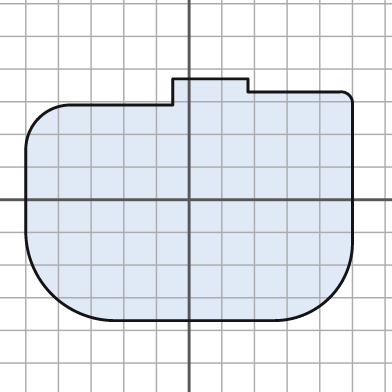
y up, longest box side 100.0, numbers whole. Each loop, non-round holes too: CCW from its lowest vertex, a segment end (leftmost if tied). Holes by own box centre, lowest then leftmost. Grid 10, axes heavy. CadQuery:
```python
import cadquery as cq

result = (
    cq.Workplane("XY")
    .moveTo(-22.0, -37.0)
    .lineTo(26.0, -37.0)
    .threePointArc((43.0, -30.0), (50.0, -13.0))
    .lineTo(50.0, 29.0)
    .threePointArc((49.0, 32.0), (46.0, 33.0))
    .lineTo(18.0, 33.0)
    .lineTo(18.0, 37.0)
    .lineTo(-5.0, 37.0)
    .lineTo(-5.0, 29.0)
    .lineTo(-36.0, 29.0)
    .threePointArc((-46.0, 25.0), (-50.0, 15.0))
    .lineTo(-50.0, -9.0)
    .threePointArc((-42.0, -29.0), (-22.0, -37.0))
    .close()
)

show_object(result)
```